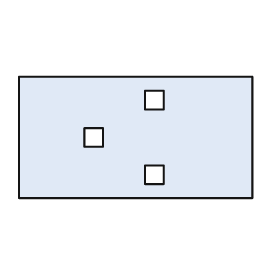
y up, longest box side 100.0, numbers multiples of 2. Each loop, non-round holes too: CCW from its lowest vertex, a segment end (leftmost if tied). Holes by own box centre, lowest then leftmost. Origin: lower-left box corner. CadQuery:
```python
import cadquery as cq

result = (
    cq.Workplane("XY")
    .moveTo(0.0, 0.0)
    .lineTo(100.0, 0.0)
    .lineTo(100.0, 52.0)
    .lineTo(0.0, 52.0)
    .close()
    .moveTo(54.0, 6.0)
    .lineTo(62.0, 6.0)
    .lineTo(62.0, 14.0)
    .lineTo(54.0, 14.0)
    .close()
    .moveTo(28.0, 22.0)
    .lineTo(36.0, 22.0)
    .lineTo(36.0, 30.0)
    .lineTo(28.0, 30.0)
    .close()
    .moveTo(54.0, 38.0)
    .lineTo(62.0, 38.0)
    .lineTo(62.0, 46.0)
    .lineTo(54.0, 46.0)
    .close()
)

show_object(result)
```